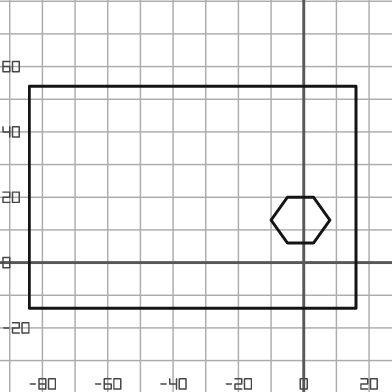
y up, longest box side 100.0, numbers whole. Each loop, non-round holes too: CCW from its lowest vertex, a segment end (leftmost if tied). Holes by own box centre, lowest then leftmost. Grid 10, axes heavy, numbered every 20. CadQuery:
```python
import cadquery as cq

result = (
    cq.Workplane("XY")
    .moveTo(-84.0, -14.0)
    .lineTo(16.0, -14.0)
    .lineTo(16.0, 54.0)
    .lineTo(-84.0, 54.0)
    .close()
    .moveTo(-5.0, 6.0)
    .lineTo(3.0, 6.0)
    .lineTo(8.0, 13.0)
    .lineTo(3.0, 20.0)
    .lineTo(-5.0, 20.0)
    .lineTo(-10.0, 13.0)
    .close()
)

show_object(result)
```